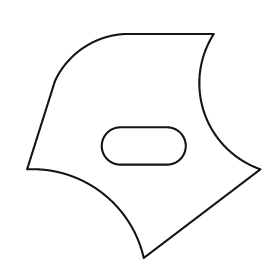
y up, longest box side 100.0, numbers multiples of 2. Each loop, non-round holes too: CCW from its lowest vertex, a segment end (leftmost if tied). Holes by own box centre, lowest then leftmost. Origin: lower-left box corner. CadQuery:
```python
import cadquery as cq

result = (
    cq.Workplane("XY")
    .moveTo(50.0, 0.0)
    .lineTo(100.0, 38.0)
    .threePointArc((76.0, 62.0), (80.0, 96.0))
    .lineTo(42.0, 96.0)
    .threePointArc((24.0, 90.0), (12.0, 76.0))
    .lineTo(0.0, 38.0)
    .threePointArc((32.0, 28.0), (50.0, 0.0))
    .close()
    .moveTo(40.0, 40.0)
    .lineTo(60.0, 40.0)
    .threePointArc((68.0, 48.0), (60.0, 56.0))
    .lineTo(40.0, 56.0)
    .threePointArc((32.0, 48.0), (40.0, 40.0))
    .close()
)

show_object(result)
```